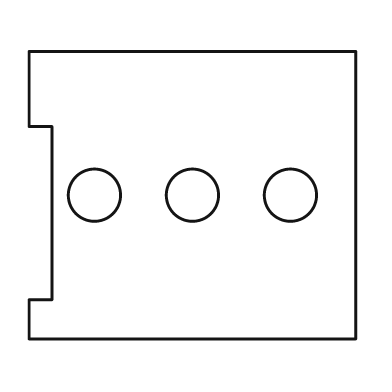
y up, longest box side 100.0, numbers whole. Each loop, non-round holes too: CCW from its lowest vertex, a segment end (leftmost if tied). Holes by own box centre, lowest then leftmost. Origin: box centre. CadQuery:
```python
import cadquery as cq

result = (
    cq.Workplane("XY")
    .moveTo(-50.0, -44.0)
    .lineTo(50.0, -44.0)
    .lineTo(50.0, 44.0)
    .lineTo(-50.0, 44.0)
    .lineTo(-50.0, 21.0)
    .lineTo(-43.0, 21.0)
    .lineTo(-43.0, -32.0)
    .lineTo(-50.0, -32.0)
    .close()
    .moveTo(-30.0, 0.0)
    .circle(8.0)
    .moveTo(0.0, 0.0)
    .circle(8.0)
    .moveTo(30.0, 0.0)
    .circle(8.0)
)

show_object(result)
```